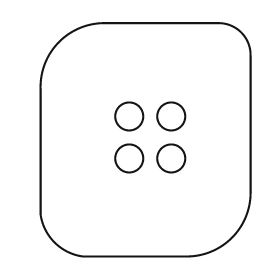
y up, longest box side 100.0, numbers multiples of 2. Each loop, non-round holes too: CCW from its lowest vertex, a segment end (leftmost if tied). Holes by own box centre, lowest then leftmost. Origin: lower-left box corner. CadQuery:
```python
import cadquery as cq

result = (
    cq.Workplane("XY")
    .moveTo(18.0, 0.0)
    .lineTo(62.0, 0.0)
    .threePointArc((82.0, 8.0), (90.0, 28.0))
    .lineTo(90.0, 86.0)
    .threePointArc((86.0, 96.0), (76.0, 100.0))
    .lineTo(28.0, 100.0)
    .threePointArc((8.0, 92.0), (0.0, 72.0))
    .lineTo(0.0, 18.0)
    .threePointArc((6.0, 6.0), (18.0, 0.0))
    .close()
    .moveTo(38.0, 42.0)
    .circle(6.0)
    .moveTo(56.0, 42.0)
    .circle(6.0)
    .moveTo(38.0, 60.0)
    .circle(6.0)
    .moveTo(56.0, 60.0)
    .circle(6.0)
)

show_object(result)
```